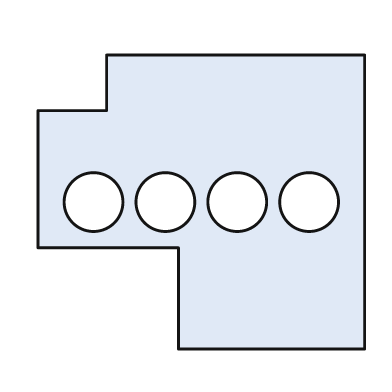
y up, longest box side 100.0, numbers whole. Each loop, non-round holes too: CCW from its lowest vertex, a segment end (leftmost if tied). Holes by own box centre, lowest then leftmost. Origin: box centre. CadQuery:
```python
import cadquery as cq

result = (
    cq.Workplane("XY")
    .moveTo(-7.0, -45.0)
    .lineTo(50.0, -45.0)
    .lineTo(50.0, 45.0)
    .lineTo(-29.0, 45.0)
    .lineTo(-29.0, 28.0)
    .lineTo(-50.0, 28.0)
    .lineTo(-50.0, -14.0)
    .lineTo(-7.0, -14.0)
    .close()
    .moveTo(-33.0, 0.0)
    .circle(9.0)
    .moveTo(-11.0, 0.0)
    .circle(9.0)
    .moveTo(11.0, 0.0)
    .circle(9.0)
    .moveTo(33.0, 0.0)
    .circle(9.0)
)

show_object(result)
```